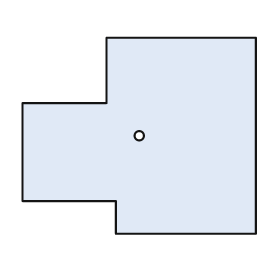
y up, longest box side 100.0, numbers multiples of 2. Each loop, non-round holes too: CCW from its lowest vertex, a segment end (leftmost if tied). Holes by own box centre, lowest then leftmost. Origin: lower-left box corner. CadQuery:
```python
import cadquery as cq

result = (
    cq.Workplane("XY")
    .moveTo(40.0, 0.0)
    .lineTo(100.0, 0.0)
    .lineTo(100.0, 84.0)
    .lineTo(36.0, 84.0)
    .lineTo(36.0, 56.0)
    .lineTo(0.0, 56.0)
    .lineTo(0.0, 14.0)
    .lineTo(40.0, 14.0)
    .close()
    .moveTo(50.0, 42.0)
    .circle(2.0)
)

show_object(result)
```